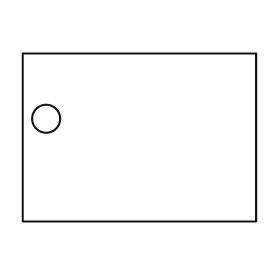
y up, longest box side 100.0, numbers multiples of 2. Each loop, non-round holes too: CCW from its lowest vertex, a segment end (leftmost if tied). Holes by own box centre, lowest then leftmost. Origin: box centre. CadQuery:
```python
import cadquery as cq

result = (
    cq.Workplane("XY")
    .moveTo(-50.0, -36.0)
    .lineTo(50.0, -36.0)
    .lineTo(50.0, 36.0)
    .lineTo(-50.0, 36.0)
    .close()
    .moveTo(-40.0, 8.0)
    .circle(6.0)
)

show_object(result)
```